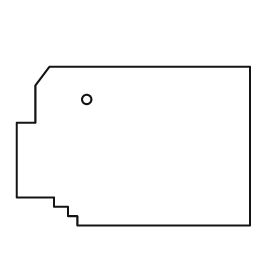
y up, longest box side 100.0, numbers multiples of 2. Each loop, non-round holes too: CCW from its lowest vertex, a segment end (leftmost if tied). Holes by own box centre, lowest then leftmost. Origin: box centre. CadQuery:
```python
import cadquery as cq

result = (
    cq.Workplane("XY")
    .moveTo(-24.0, -34.0)
    .lineTo(50.0, -34.0)
    .lineTo(50.0, 34.0)
    .lineTo(-36.0, 34.0)
    .lineTo(-42.0, 26.0)
    .lineTo(-42.0, 10.0)
    .lineTo(-50.0, 10.0)
    .lineTo(-50.0, -22.0)
    .lineTo(-34.0, -22.0)
    .lineTo(-34.0, -26.0)
    .lineTo(-28.0, -26.0)
    .lineTo(-28.0, -30.0)
    .lineTo(-24.0, -30.0)
    .close()
    .moveTo(-20.0, 20.0)
    .circle(2.0)
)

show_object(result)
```